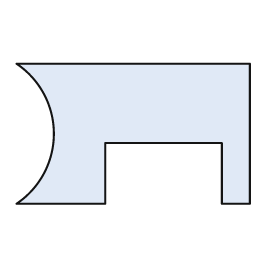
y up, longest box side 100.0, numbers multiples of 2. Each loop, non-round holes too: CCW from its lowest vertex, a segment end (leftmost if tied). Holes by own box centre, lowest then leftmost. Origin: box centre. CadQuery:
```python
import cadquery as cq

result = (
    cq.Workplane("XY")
    .moveTo(-50.0, -30.0)
    .lineTo(-12.0, -30.0)
    .lineTo(-12.0, -4.0)
    .lineTo(38.0, -4.0)
    .lineTo(38.0, -30.0)
    .lineTo(50.0, -30.0)
    .lineTo(50.0, 30.0)
    .lineTo(-50.0, 30.0)
    .threePointArc((-34.0, 0.0), (-50.0, -30.0))
    .close()
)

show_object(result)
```